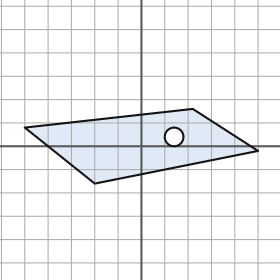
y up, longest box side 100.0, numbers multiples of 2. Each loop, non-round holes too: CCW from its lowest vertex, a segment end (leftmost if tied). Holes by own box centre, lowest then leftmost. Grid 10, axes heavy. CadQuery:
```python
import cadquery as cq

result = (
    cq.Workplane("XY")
    .moveTo(-20.0, -16.0)
    .lineTo(50.0, -2.0)
    .lineTo(22.0, 16.0)
    .lineTo(-50.0, 8.0)
    .close()
    .moveTo(14.0, 4.0)
    .circle(4.0)
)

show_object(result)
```